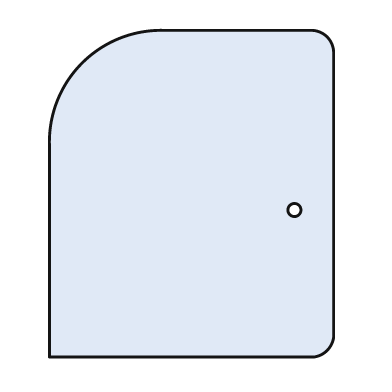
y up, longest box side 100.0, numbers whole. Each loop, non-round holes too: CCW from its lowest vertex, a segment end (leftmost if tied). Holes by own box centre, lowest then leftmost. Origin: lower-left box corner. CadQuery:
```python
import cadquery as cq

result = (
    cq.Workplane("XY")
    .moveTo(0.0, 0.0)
    .lineTo(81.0, 0.0)
    .threePointArc((85.0, 2.0), (87.0, 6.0))
    .lineTo(87.0, 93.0)
    .threePointArc((85.0, 98.0), (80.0, 100.0))
    .lineTo(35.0, 100.0)
    .threePointArc((10.0, 90.0), (0.0, 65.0))
    .close()
    .moveTo(75.0, 45.0)
    .circle(2.0)
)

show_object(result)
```